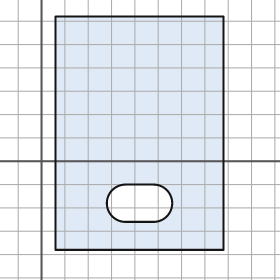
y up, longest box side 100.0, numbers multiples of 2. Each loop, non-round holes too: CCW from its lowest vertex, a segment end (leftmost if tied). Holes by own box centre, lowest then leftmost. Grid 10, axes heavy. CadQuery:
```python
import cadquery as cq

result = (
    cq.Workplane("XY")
    .moveTo(6.0, -38.0)
    .lineTo(78.0, -38.0)
    .lineTo(78.0, 62.0)
    .lineTo(6.0, 62.0)
    .close()
    .moveTo(36.0, -26.0)
    .lineTo(48.0, -26.0)
    .threePointArc((56.0, -18.0), (48.0, -10.0))
    .lineTo(36.0, -10.0)
    .threePointArc((28.0, -18.0), (36.0, -26.0))
    .close()
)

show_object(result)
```